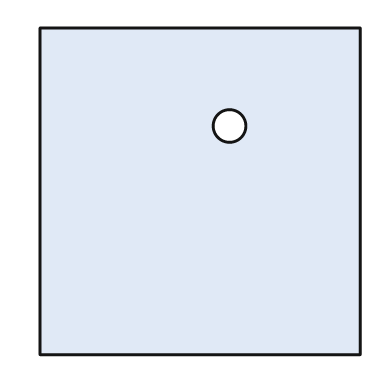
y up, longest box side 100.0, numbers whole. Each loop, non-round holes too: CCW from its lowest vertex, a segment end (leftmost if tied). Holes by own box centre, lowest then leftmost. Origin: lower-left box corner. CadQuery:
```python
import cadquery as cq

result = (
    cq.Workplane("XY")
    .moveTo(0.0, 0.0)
    .lineTo(98.0, 0.0)
    .lineTo(98.0, 100.0)
    .lineTo(0.0, 100.0)
    .close()
    .moveTo(58.0, 70.0)
    .circle(5.0)
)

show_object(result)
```